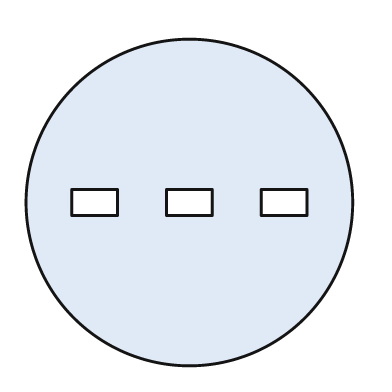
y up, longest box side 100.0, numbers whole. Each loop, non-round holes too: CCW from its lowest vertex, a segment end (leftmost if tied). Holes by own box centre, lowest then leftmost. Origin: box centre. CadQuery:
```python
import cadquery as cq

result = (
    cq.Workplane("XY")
    .moveTo(0.0, 0.0)
    .circle(50.0)
    .moveTo(-36.0, -4.0)
    .lineTo(-22.0, -4.0)
    .lineTo(-22.0, 4.0)
    .lineTo(-36.0, 4.0)
    .close()
    .moveTo(-7.0, -4.0)
    .lineTo(7.0, -4.0)
    .lineTo(7.0, 4.0)
    .lineTo(-7.0, 4.0)
    .close()
    .moveTo(22.0, -4.0)
    .lineTo(36.0, -4.0)
    .lineTo(36.0, 4.0)
    .lineTo(22.0, 4.0)
    .close()
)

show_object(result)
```